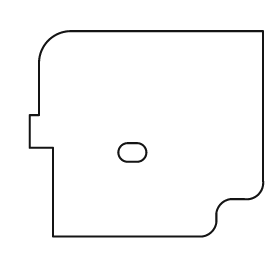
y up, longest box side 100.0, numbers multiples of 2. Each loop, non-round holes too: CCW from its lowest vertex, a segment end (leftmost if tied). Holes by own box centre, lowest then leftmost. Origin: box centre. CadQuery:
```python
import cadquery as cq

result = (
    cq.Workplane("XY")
    .moveTo(-40.0, -44.0)
    .lineTo(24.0, -44.0)
    .threePointArc((28.0, -42.0), (30.0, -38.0))
    .lineTo(30.0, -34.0)
    .threePointArc((32.0, -30.0), (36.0, -28.0))
    .lineTo(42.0, -28.0)
    .threePointArc((48.0, -26.0), (50.0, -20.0))
    .lineTo(50.0, 44.0)
    .lineTo(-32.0, 44.0)
    .threePointArc((-42.0, 40.0), (-46.0, 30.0))
    .lineTo(-46.0, 8.0)
    .lineTo(-50.0, 8.0)
    .lineTo(-50.0, -6.0)
    .lineTo(-40.0, -6.0)
    .close()
    .moveTo(-8.0, -12.0)
    .lineTo(-4.0, -12.0)
    .threePointArc((0.0, -8.0), (-4.0, -4.0))
    .lineTo(-8.0, -4.0)
    .threePointArc((-12.0, -8.0), (-8.0, -12.0))
    .close()
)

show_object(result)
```